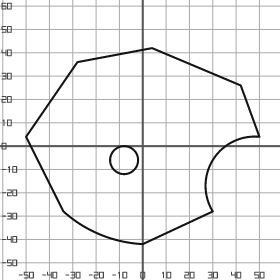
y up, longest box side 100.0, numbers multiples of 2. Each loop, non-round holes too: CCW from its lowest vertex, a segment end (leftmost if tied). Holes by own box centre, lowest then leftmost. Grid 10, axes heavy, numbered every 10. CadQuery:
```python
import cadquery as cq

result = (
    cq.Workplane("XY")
    .moveTo(0.0, -42.0)
    .lineTo(30.0, -28.0)
    .threePointArc((30.0, -6.0), (50.0, 4.0))
    .lineTo(42.0, 26.0)
    .lineTo(4.0, 42.0)
    .lineTo(-28.0, 36.0)
    .lineTo(-50.0, 4.0)
    .lineTo(-34.0, -28.0)
    .threePointArc((-18.0, -38.0), (0.0, -42.0))
    .close()
    .moveTo(-8.0, -6.0)
    .circle(6.0)
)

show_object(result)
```